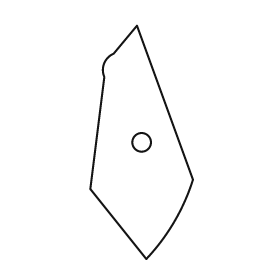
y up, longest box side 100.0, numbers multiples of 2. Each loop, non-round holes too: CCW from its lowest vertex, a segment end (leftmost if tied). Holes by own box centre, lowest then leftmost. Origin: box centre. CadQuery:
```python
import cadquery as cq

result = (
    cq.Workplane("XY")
    .moveTo(2.0, -50.0)
    .threePointArc((14.0, -34.0), (22.0, -16.0))
    .lineTo(-2.0, 50.0)
    .lineTo(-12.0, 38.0)
    .threePointArc((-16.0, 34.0), (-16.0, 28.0))
    .lineTo(-22.0, -20.0)
    .close()
    .moveTo(0.0, 0.0)
    .circle(4.0)
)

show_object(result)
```